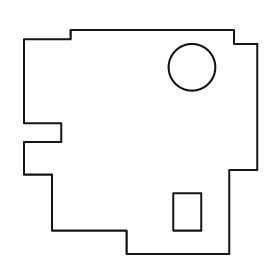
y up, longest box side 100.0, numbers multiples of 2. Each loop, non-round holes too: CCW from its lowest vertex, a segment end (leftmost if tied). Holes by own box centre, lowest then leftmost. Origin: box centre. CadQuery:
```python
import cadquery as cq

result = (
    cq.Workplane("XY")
    .moveTo(-6.0, -48.0)
    .lineTo(38.0, -48.0)
    .lineTo(38.0, -12.0)
    .lineTo(50.0, -12.0)
    .lineTo(50.0, 42.0)
    .lineTo(40.0, 42.0)
    .lineTo(40.0, 48.0)
    .lineTo(-30.0, 48.0)
    .lineTo(-30.0, 44.0)
    .lineTo(-50.0, 44.0)
    .lineTo(-50.0, 8.0)
    .lineTo(-34.0, 8.0)
    .lineTo(-34.0, 0.0)
    .lineTo(-50.0, 0.0)
    .lineTo(-50.0, -14.0)
    .lineTo(-38.0, -14.0)
    .lineTo(-38.0, -38.0)
    .lineTo(-6.0, -38.0)
    .close()
    .moveTo(14.0, -38.0)
    .lineTo(26.0, -38.0)
    .lineTo(26.0, -22.0)
    .lineTo(14.0, -22.0)
    .close()
    .moveTo(22.0, 32.0)
    .circle(10.0)
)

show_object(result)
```